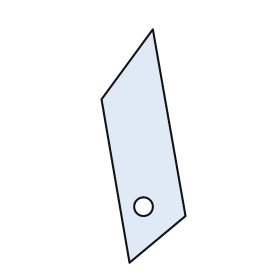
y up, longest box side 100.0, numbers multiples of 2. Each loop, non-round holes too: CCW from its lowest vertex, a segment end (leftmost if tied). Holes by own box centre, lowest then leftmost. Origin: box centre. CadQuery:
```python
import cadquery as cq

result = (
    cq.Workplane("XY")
    .moveTo(-6.0, -50.0)
    .lineTo(18.0, -30.0)
    .lineTo(4.0, 50.0)
    .lineTo(-18.0, 20.0)
    .close()
    .moveTo(0.0, -26.0)
    .circle(4.0)
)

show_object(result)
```